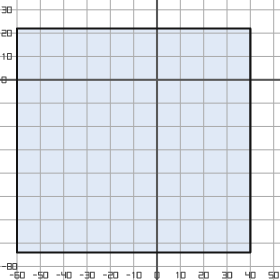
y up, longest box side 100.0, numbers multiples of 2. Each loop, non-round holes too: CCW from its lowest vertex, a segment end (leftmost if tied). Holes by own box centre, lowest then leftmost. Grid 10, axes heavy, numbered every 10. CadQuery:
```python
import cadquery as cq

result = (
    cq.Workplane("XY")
    .moveTo(-60.0, -74.0)
    .lineTo(40.0, -74.0)
    .lineTo(40.0, 22.0)
    .lineTo(-60.0, 22.0)
    .close()
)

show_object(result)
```